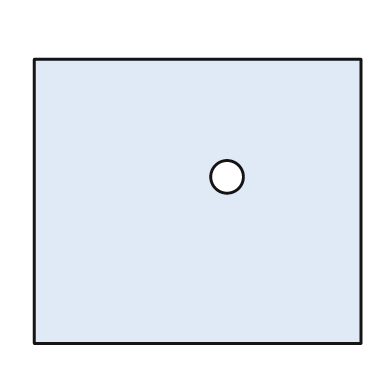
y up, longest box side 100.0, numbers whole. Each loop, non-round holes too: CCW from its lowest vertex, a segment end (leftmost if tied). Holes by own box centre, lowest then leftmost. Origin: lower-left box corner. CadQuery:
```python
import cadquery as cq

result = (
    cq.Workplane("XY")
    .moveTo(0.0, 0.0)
    .lineTo(100.0, 0.0)
    .lineTo(100.0, 87.0)
    .lineTo(0.0, 87.0)
    .close()
    .moveTo(59.0, 51.0)
    .circle(5.0)
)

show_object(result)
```